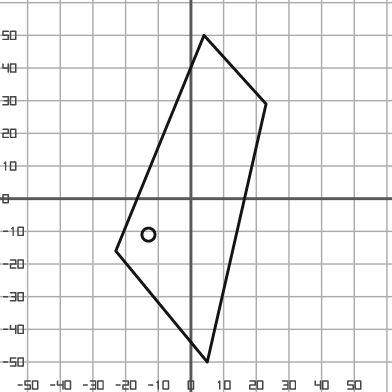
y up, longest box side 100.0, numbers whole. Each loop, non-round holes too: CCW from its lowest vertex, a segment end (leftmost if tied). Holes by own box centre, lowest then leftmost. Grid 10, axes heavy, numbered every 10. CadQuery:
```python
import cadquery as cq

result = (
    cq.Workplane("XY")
    .moveTo(5.0, -50.0)
    .lineTo(23.0, 29.0)
    .lineTo(4.0, 50.0)
    .lineTo(-23.0, -16.0)
    .close()
    .moveTo(-13.0, -11.0)
    .circle(2.0)
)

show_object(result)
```